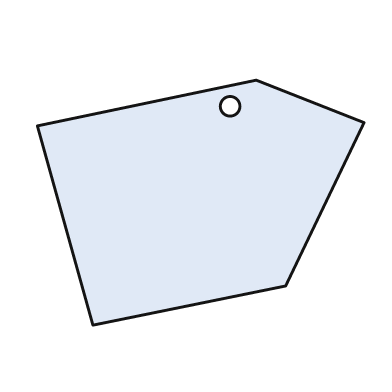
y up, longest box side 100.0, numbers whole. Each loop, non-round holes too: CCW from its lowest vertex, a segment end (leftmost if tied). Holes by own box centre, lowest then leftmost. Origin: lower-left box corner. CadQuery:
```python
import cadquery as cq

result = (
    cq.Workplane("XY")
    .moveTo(17.0, 0.0)
    .lineTo(76.0, 12.0)
    .lineTo(100.0, 62.0)
    .lineTo(67.0, 75.0)
    .lineTo(0.0, 61.0)
    .close()
    .moveTo(59.0, 67.0)
    .circle(3.0)
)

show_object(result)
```